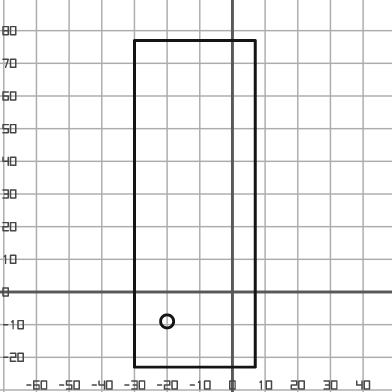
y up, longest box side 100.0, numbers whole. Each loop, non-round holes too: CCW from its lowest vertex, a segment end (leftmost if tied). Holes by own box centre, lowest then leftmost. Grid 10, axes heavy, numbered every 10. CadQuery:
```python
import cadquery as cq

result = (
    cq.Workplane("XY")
    .moveTo(-30.0, -23.0)
    .lineTo(7.0, -23.0)
    .lineTo(7.0, 77.0)
    .lineTo(-30.0, 77.0)
    .close()
    .moveTo(-20.0, -9.0)
    .circle(2.0)
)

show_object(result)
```